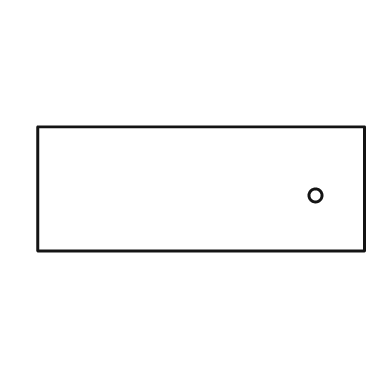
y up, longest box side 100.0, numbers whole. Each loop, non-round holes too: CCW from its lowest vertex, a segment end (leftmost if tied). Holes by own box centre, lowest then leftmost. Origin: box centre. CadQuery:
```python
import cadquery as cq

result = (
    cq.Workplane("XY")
    .moveTo(-50.0, -19.0)
    .lineTo(50.0, -19.0)
    .lineTo(50.0, 19.0)
    .lineTo(-50.0, 19.0)
    .close()
    .moveTo(35.0, -2.0)
    .circle(2.0)
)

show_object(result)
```